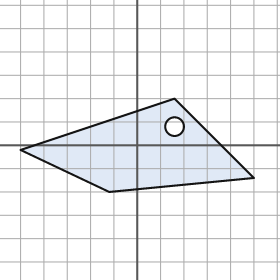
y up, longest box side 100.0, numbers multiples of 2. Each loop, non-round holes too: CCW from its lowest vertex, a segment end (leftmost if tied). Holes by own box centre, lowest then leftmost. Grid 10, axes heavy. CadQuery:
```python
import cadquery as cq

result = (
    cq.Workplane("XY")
    .moveTo(-12.0, -20.0)
    .lineTo(50.0, -14.0)
    .lineTo(16.0, 20.0)
    .lineTo(-50.0, -2.0)
    .close()
    .moveTo(16.0, 8.0)
    .circle(4.0)
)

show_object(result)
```